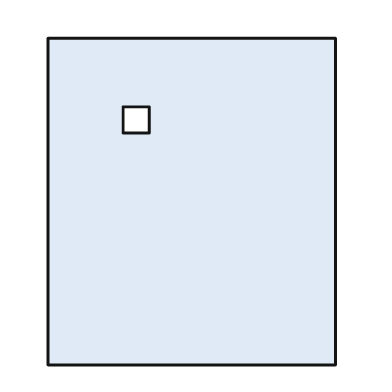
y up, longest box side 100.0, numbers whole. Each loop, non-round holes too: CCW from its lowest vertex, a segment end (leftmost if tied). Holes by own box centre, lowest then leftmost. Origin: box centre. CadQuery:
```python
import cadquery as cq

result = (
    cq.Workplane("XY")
    .moveTo(-44.0, -50.0)
    .lineTo(44.0, -50.0)
    .lineTo(44.0, 50.0)
    .lineTo(-44.0, 50.0)
    .close()
    .moveTo(-21.0, 21.0)
    .lineTo(-13.0, 21.0)
    .lineTo(-13.0, 29.0)
    .lineTo(-21.0, 29.0)
    .close()
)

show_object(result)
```